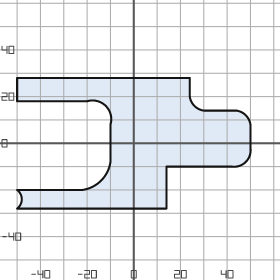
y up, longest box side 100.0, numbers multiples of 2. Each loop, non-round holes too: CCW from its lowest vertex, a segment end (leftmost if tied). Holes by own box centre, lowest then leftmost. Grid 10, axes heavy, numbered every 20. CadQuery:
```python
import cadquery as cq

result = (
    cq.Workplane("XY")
    .moveTo(-50.0, -28.0)
    .lineTo(14.0, -28.0)
    .lineTo(14.0, -10.0)
    .lineTo(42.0, -10.0)
    .threePointArc((48.0, -8.0), (50.0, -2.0))
    .lineTo(50.0, 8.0)
    .threePointArc((48.0, 12.0), (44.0, 14.0))
    .lineTo(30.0, 14.0)
    .threePointArc((26.0, 16.0), (24.0, 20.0))
    .lineTo(24.0, 28.0)
    .lineTo(-50.0, 28.0)
    .lineTo(-50.0, 18.0)
    .lineTo(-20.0, 18.0)
    .threePointArc((-12.0, 16.0), (-10.0, 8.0))
    .lineTo(-10.0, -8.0)
    .threePointArc((-14.0, -16.0), (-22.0, -20.0))
    .lineTo(-50.0, -20.0)
    .threePointArc((-48.0, -24.0), (-50.0, -28.0))
    .close()
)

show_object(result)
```